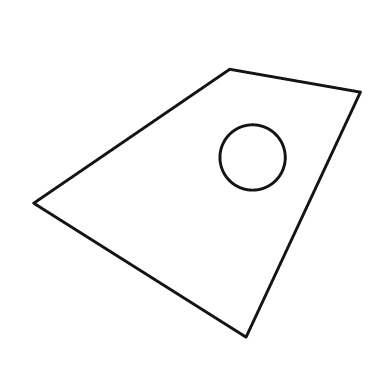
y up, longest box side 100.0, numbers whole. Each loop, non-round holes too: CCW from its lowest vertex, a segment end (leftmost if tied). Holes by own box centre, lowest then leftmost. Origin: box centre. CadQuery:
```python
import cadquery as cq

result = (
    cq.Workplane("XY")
    .moveTo(15.0, -41.0)
    .lineTo(50.0, 34.0)
    .lineTo(10.0, 41.0)
    .lineTo(-50.0, 0.0)
    .close()
    .moveTo(17.0, 14.0)
    .circle(10.0)
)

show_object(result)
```